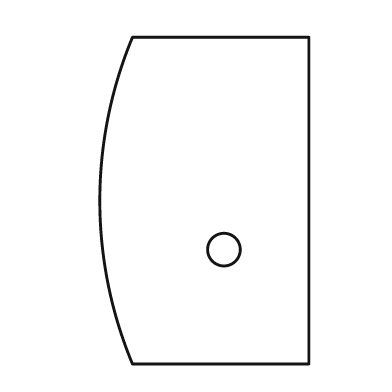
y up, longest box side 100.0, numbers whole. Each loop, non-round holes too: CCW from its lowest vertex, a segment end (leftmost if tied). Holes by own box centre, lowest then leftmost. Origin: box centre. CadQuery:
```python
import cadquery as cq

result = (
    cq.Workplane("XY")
    .moveTo(-22.0, -50.0)
    .lineTo(32.0, -50.0)
    .lineTo(32.0, 50.0)
    .lineTo(-22.0, 50.0)
    .threePointArc((-32.0, 0.0), (-22.0, -50.0))
    .close()
    .moveTo(6.0, -15.0)
    .circle(5.0)
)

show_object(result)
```